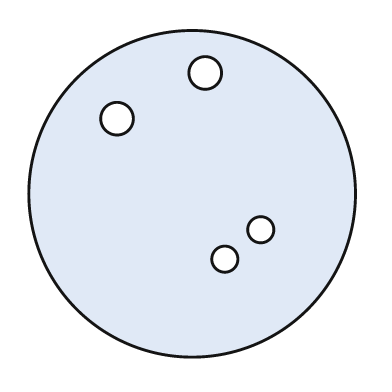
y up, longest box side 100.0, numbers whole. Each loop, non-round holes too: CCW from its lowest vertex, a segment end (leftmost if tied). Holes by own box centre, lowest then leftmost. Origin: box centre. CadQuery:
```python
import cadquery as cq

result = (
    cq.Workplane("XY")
    .moveTo(0.0, 0.0)
    .circle(50.0)
    .moveTo(10.0, -20.0)
    .circle(4.0)
    .moveTo(21.0, -11.0)
    .circle(4.0)
    .moveTo(-23.0, 23.0)
    .circle(5.0)
    .moveTo(4.0, 37.0)
    .circle(5.0)
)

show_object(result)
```